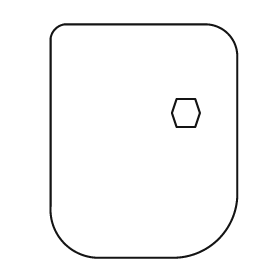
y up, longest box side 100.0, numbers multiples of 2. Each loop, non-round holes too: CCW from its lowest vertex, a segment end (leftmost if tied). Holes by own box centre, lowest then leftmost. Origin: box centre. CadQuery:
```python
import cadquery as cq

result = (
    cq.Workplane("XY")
    .moveTo(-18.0, -50.0)
    .lineTo(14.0, -50.0)
    .threePointArc((32.0, -42.0), (40.0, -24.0))
    .lineTo(40.0, 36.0)
    .threePointArc((36.0, 46.0), (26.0, 50.0))
    .lineTo(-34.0, 50.0)
    .threePointArc((-38.0, 48.0), (-40.0, 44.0))
    .lineTo(-40.0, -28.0)
    .threePointArc((-34.0, -44.0), (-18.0, -50.0))
    .close()
    .moveTo(14.0, 6.0)
    .lineTo(22.0, 6.0)
    .lineTo(24.0, 12.0)
    .lineTo(22.0, 18.0)
    .lineTo(14.0, 18.0)
    .lineTo(12.0, 12.0)
    .close()
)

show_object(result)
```